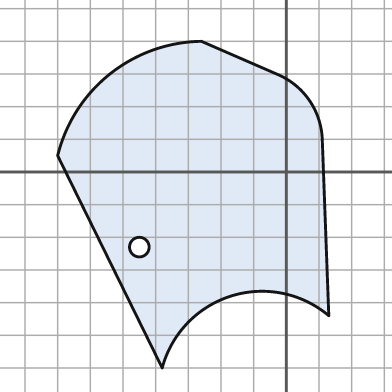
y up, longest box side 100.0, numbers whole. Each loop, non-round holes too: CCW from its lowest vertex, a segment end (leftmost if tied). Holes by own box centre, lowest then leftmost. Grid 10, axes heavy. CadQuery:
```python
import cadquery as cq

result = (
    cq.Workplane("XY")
    .moveTo(-38.0, -60.0)
    .threePointArc((-17.0, -38.0), (13.0, -44.0))
    .lineTo(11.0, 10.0)
    .threePointArc((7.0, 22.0), (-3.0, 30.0))
    .lineTo(-26.0, 40.0)
    .threePointArc((-54.0, 30.0), (-70.0, 5.0))
    .close()
    .moveTo(-45.0, -23.0)
    .circle(3.0)
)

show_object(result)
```